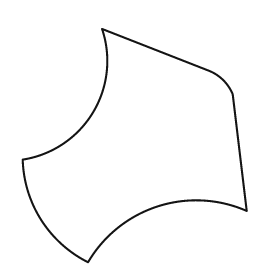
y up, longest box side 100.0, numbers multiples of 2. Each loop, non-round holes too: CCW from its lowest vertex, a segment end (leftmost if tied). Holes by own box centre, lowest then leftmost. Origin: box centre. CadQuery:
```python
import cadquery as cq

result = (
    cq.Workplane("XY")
    .moveTo(-20.0, -50.0)
    .threePointArc((10.0, -26.0), (48.0, -28.0))
    .lineTo(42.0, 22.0)
    .threePointArc((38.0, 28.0), (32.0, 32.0))
    .lineTo(-14.0, 50.0)
    .threePointArc((-18.0, 14.0), (-48.0, -6.0))
    .threePointArc((-40.0, -32.0), (-20.0, -50.0))
    .close()
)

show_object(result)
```